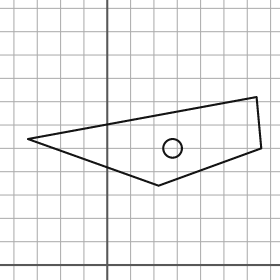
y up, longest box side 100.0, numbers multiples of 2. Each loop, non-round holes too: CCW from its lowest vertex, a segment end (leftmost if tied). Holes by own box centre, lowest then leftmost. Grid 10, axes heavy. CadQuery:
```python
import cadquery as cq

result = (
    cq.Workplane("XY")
    .moveTo(22.0, 34.0)
    .lineTo(66.0, 50.0)
    .lineTo(64.0, 72.0)
    .lineTo(-34.0, 54.0)
    .close()
    .moveTo(28.0, 50.0)
    .circle(4.0)
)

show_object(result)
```